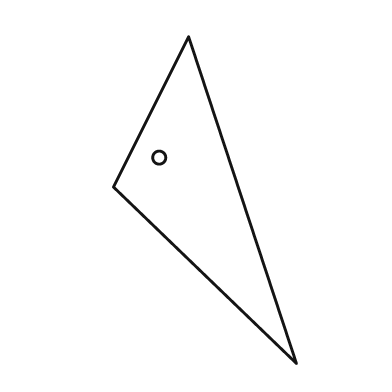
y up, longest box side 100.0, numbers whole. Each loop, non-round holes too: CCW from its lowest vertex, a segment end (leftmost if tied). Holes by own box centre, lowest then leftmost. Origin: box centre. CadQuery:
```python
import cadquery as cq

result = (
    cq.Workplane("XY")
    .moveTo(28.0, -50.0)
    .lineTo(-5.0, 50.0)
    .lineTo(-28.0, 4.0)
    .close()
    .moveTo(-14.0, 13.0)
    .circle(2.0)
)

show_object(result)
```